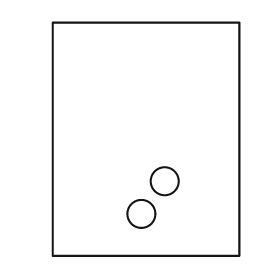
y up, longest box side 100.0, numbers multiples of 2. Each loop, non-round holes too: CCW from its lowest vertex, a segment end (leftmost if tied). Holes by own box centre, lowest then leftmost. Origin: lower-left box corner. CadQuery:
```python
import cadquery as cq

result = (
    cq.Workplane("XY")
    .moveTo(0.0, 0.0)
    .lineTo(80.0, 0.0)
    .lineTo(80.0, 100.0)
    .lineTo(0.0, 100.0)
    .close()
    .moveTo(38.0, 18.0)
    .circle(6.0)
    .moveTo(48.0, 32.0)
    .circle(6.0)
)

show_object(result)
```